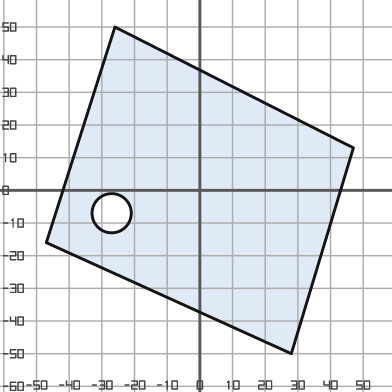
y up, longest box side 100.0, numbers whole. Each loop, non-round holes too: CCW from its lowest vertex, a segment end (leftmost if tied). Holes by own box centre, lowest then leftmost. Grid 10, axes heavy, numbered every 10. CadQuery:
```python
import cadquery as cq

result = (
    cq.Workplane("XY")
    .moveTo(28.0, -50.0)
    .lineTo(47.0, 13.0)
    .lineTo(-26.0, 50.0)
    .lineTo(-47.0, -16.0)
    .close()
    .moveTo(-27.0, -7.0)
    .circle(6.0)
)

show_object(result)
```